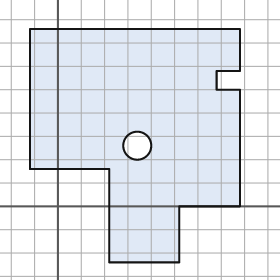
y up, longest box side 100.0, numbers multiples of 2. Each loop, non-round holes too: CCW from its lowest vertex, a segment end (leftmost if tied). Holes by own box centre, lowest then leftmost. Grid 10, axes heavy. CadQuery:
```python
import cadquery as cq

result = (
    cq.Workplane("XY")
    .moveTo(22.0, -24.0)
    .lineTo(52.0, -24.0)
    .lineTo(52.0, 0.0)
    .lineTo(78.0, 0.0)
    .lineTo(78.0, 50.0)
    .lineTo(68.0, 50.0)
    .lineTo(68.0, 58.0)
    .lineTo(78.0, 58.0)
    .lineTo(78.0, 76.0)
    .lineTo(-12.0, 76.0)
    .lineTo(-12.0, 16.0)
    .lineTo(22.0, 16.0)
    .close()
    .moveTo(34.0, 26.0)
    .circle(6.0)
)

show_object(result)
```